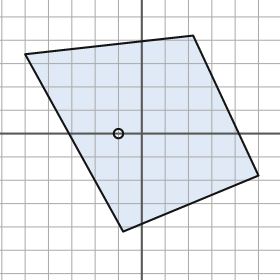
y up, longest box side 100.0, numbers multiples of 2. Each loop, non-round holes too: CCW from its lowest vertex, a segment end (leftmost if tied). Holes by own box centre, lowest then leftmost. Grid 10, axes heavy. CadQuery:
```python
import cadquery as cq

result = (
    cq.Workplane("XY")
    .moveTo(-8.0, -42.0)
    .lineTo(50.0, -18.0)
    .lineTo(22.0, 42.0)
    .lineTo(-50.0, 34.0)
    .close()
    .moveTo(-10.0, 0.0)
    .circle(2.0)
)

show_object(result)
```